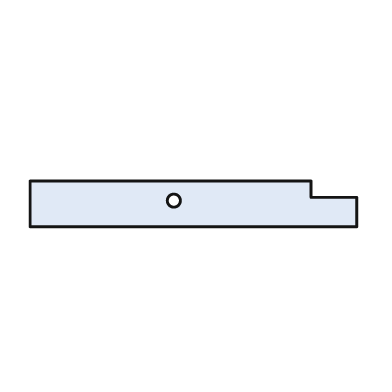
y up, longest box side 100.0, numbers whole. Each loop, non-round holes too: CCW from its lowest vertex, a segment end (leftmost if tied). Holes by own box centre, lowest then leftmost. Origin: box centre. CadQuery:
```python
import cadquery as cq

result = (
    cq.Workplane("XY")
    .moveTo(-50.0, -7.0)
    .lineTo(50.0, -7.0)
    .lineTo(50.0, 2.0)
    .lineTo(36.0, 2.0)
    .lineTo(36.0, 7.0)
    .lineTo(-50.0, 7.0)
    .close()
    .moveTo(-6.0, 1.0)
    .circle(2.0)
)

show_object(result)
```